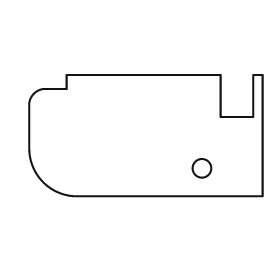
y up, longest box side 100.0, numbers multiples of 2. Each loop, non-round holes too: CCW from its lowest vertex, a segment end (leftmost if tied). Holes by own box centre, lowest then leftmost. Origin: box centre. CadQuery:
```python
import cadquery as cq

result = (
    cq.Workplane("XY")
    .moveTo(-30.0, -26.0)
    .lineTo(50.0, -26.0)
    .lineTo(50.0, 26.0)
    .lineTo(46.0, 26.0)
    .lineTo(46.0, 8.0)
    .lineTo(32.0, 8.0)
    .lineTo(32.0, 26.0)
    .lineTo(-34.0, 26.0)
    .lineTo(-34.0, 20.0)
    .lineTo(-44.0, 20.0)
    .threePointArc((-48.0, 18.0), (-50.0, 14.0))
    .lineTo(-50.0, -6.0)
    .threePointArc((-44.0, -20.0), (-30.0, -26.0))
    .close()
    .moveTo(24.0, -14.0)
    .circle(4.0)
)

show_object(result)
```